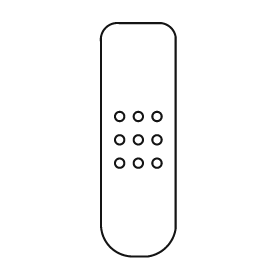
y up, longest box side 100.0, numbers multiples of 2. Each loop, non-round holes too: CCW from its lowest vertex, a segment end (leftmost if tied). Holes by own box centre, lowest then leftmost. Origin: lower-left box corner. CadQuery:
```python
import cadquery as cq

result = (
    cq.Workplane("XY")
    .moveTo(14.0, 0.0)
    .lineTo(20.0, 0.0)
    .threePointArc((28.0, 4.0), (32.0, 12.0))
    .lineTo(32.0, 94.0)
    .threePointArc((30.0, 98.0), (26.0, 100.0))
    .lineTo(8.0, 100.0)
    .threePointArc((2.0, 98.0), (0.0, 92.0))
    .lineTo(0.0, 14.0)
    .threePointArc((4.0, 4.0), (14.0, 0.0))
    .close()
    .moveTo(8.0, 40.0)
    .circle(2.0)
    .moveTo(16.0, 40.0)
    .circle(2.0)
    .moveTo(24.0, 40.0)
    .circle(2.0)
    .moveTo(8.0, 50.0)
    .circle(2.0)
    .moveTo(16.0, 50.0)
    .circle(2.0)
    .moveTo(24.0, 50.0)
    .circle(2.0)
    .moveTo(8.0, 60.0)
    .circle(2.0)
    .moveTo(16.0, 60.0)
    .circle(2.0)
    .moveTo(24.0, 60.0)
    .circle(2.0)
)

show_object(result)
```